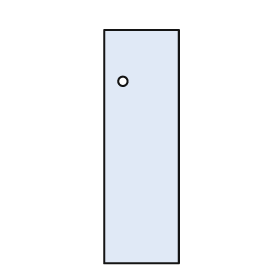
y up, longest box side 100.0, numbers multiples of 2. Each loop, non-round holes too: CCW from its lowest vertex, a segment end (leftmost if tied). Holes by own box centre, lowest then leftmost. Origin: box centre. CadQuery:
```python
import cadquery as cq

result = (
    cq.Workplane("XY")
    .moveTo(-16.0, -50.0)
    .lineTo(16.0, -50.0)
    .lineTo(16.0, 50.0)
    .lineTo(-16.0, 50.0)
    .close()
    .moveTo(-8.0, 28.0)
    .circle(2.0)
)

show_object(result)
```